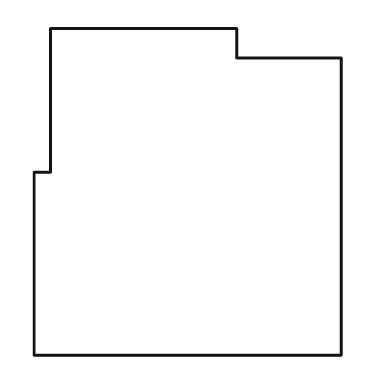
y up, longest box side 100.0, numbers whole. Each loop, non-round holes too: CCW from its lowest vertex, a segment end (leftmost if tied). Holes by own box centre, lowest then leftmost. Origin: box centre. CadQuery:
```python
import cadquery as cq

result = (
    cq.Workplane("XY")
    .moveTo(-47.0, -50.0)
    .lineTo(47.0, -50.0)
    .lineTo(47.0, 41.0)
    .lineTo(15.0, 41.0)
    .lineTo(15.0, 50.0)
    .lineTo(-42.0, 50.0)
    .lineTo(-42.0, 6.0)
    .lineTo(-47.0, 6.0)
    .close()
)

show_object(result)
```